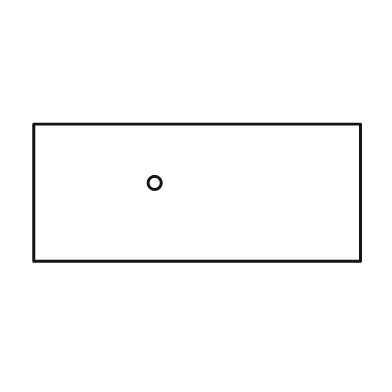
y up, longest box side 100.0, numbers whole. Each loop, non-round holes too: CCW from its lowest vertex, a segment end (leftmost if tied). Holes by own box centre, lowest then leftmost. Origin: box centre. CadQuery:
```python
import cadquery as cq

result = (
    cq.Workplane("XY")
    .moveTo(-50.0, -21.0)
    .lineTo(50.0, -21.0)
    .lineTo(50.0, 21.0)
    .lineTo(-50.0, 21.0)
    .close()
    .moveTo(-13.0, 3.0)
    .circle(2.0)
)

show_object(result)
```